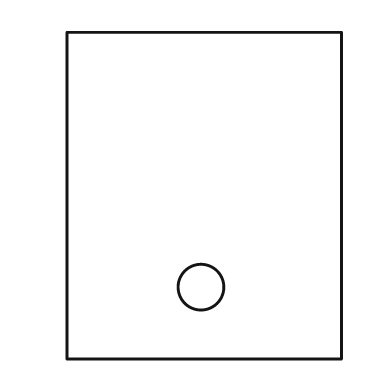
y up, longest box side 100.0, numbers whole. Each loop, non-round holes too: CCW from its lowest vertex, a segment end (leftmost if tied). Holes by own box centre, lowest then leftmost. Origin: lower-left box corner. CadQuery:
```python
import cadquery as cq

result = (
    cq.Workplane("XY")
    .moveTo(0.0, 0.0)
    .lineTo(84.0, 0.0)
    .lineTo(84.0, 100.0)
    .lineTo(0.0, 100.0)
    .close()
    .moveTo(41.0, 22.0)
    .circle(7.0)
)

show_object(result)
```